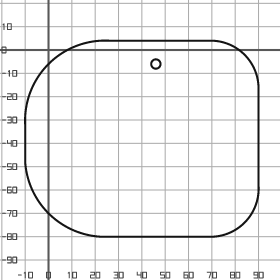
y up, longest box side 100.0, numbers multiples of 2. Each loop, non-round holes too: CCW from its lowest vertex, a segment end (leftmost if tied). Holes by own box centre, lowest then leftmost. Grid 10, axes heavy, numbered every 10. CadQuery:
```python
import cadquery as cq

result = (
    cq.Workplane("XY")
    .moveTo(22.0, -80.0)
    .lineTo(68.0, -80.0)
    .threePointArc((84.0, -74.0), (90.0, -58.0))
    .lineTo(90.0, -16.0)
    .threePointArc((84.0, -2.0), (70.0, 4.0))
    .lineTo(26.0, 4.0)
    .threePointArc((0.0, -6.0), (-10.0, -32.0))
    .lineTo(-10.0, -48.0)
    .threePointArc((0.0, -70.0), (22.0, -80.0))
    .close()
    .moveTo(46.0, -6.0)
    .circle(2.0)
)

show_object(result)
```